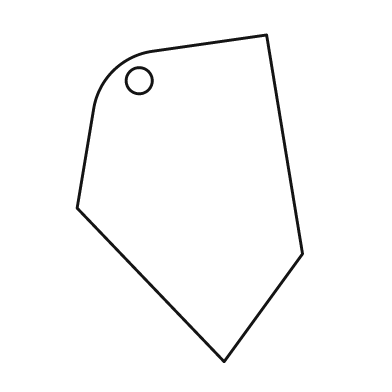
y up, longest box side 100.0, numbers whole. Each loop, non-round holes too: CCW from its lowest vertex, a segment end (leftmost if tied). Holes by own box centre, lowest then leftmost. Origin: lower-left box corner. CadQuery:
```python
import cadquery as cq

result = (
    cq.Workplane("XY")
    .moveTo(45.0, 0.0)
    .lineTo(69.0, 33.0)
    .lineTo(58.0, 100.0)
    .lineTo(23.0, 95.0)
    .threePointArc((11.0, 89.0), (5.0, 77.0))
    .lineTo(0.0, 47.0)
    .close()
    .moveTo(19.0, 86.0)
    .circle(4.0)
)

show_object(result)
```